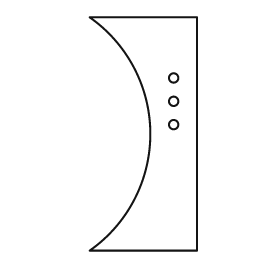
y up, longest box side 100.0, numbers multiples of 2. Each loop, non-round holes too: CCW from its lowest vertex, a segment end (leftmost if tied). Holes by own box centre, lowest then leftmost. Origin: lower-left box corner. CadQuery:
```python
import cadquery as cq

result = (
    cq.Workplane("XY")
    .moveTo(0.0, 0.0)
    .lineTo(46.0, 0.0)
    .lineTo(46.0, 100.0)
    .lineTo(0.0, 100.0)
    .threePointArc((26.0, 50.0), (0.0, 0.0))
    .close()
    .moveTo(36.0, 54.0)
    .circle(2.0)
    .moveTo(36.0, 64.0)
    .circle(2.0)
    .moveTo(36.0, 74.0)
    .circle(2.0)
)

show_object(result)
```